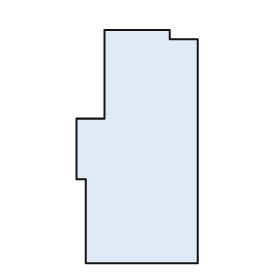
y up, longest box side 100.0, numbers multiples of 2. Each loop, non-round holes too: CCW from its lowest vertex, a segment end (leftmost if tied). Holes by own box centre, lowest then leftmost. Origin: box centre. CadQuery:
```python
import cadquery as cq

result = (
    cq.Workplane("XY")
    .moveTo(-22.0, -50.0)
    .lineTo(26.0, -50.0)
    .lineTo(26.0, 46.0)
    .lineTo(14.0, 46.0)
    .lineTo(14.0, 50.0)
    .lineTo(-14.0, 50.0)
    .lineTo(-14.0, 12.0)
    .lineTo(-26.0, 12.0)
    .lineTo(-26.0, -14.0)
    .lineTo(-22.0, -14.0)
    .close()
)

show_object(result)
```